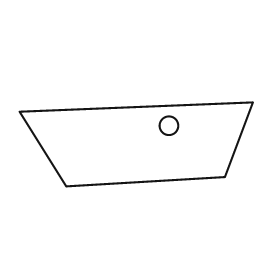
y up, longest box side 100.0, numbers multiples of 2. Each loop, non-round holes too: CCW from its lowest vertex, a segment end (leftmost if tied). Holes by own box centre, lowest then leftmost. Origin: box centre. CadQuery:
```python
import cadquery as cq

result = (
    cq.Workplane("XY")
    .moveTo(-30.0, -18.0)
    .lineTo(38.0, -14.0)
    .lineTo(50.0, 18.0)
    .lineTo(-50.0, 14.0)
    .close()
    .moveTo(14.0, 8.0)
    .circle(4.0)
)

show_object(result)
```